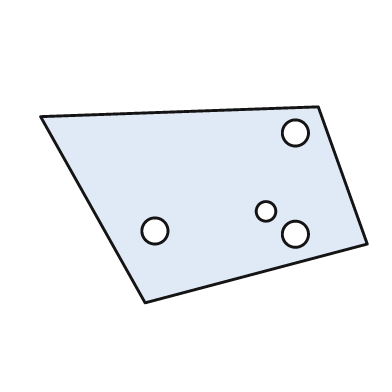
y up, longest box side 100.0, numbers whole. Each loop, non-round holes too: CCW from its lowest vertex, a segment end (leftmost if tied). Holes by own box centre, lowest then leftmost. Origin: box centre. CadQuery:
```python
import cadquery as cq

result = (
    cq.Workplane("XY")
    .moveTo(-18.0, -30.0)
    .lineTo(50.0, -12.0)
    .lineTo(35.0, 30.0)
    .lineTo(-50.0, 27.0)
    .close()
    .moveTo(28.0, -9.0)
    .circle(4.0)
    .moveTo(-15.0, -8.0)
    .circle(4.0)
    .moveTo(19.0, -2.0)
    .circle(3.0)
    .moveTo(28.0, 22.0)
    .circle(4.0)
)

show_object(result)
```